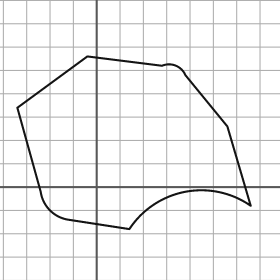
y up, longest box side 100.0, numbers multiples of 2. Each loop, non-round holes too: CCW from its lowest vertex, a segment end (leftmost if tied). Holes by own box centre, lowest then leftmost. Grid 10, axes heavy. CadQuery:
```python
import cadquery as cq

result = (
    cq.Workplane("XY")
    .moveTo(14.0, -18.0)
    .threePointArc((38.0, -2.0), (66.0, -8.0))
    .lineTo(56.0, 26.0)
    .lineTo(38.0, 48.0)
    .threePointArc((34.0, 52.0), (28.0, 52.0))
    .lineTo(-4.0, 56.0)
    .lineTo(-34.0, 34.0)
    .lineTo(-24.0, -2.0)
    .threePointArc((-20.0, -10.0), (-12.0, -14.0))
    .close()
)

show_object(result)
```